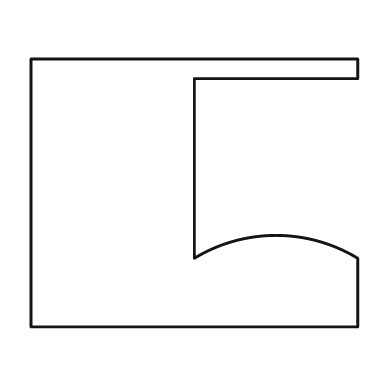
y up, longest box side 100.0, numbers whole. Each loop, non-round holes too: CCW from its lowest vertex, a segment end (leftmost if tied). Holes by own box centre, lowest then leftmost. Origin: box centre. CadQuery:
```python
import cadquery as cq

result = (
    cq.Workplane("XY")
    .moveTo(-50.0, -41.0)
    .lineTo(50.0, -41.0)
    .lineTo(50.0, -20.0)
    .threePointArc((25.0, -13.0), (0.0, -20.0))
    .lineTo(0.0, 35.0)
    .lineTo(50.0, 35.0)
    .lineTo(50.0, 41.0)
    .lineTo(-50.0, 41.0)
    .close()
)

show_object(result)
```